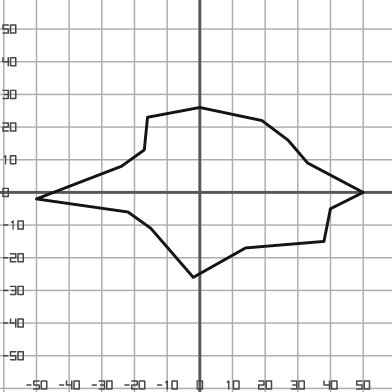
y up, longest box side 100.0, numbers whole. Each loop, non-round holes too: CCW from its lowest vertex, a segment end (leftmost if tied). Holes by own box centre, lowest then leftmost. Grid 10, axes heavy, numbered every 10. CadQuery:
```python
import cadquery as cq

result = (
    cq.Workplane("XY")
    .moveTo(-2.0, -26.0)
    .lineTo(14.0, -17.0)
    .lineTo(38.0, -15.0)
    .lineTo(40.0, -5.0)
    .lineTo(50.0, 0.0)
    .lineTo(33.0, 9.0)
    .lineTo(27.0, 16.0)
    .lineTo(19.0, 22.0)
    .lineTo(0.0, 26.0)
    .lineTo(-16.0, 23.0)
    .lineTo(-17.0, 13.0)
    .lineTo(-24.0, 8.0)
    .lineTo(-50.0, -2.0)
    .lineTo(-22.0, -6.0)
    .lineTo(-15.0, -11.0)
    .close()
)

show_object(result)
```